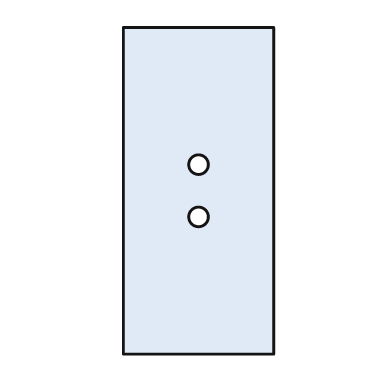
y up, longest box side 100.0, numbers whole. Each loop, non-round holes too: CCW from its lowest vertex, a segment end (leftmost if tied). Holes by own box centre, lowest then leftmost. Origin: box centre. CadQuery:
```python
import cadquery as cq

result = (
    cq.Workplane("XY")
    .moveTo(-23.0, -50.0)
    .lineTo(23.0, -50.0)
    .lineTo(23.0, 50.0)
    .lineTo(-23.0, 50.0)
    .close()
    .moveTo(0.0, -8.0)
    .circle(3.0)
    .moveTo(0.0, 8.0)
    .circle(3.0)
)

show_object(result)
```